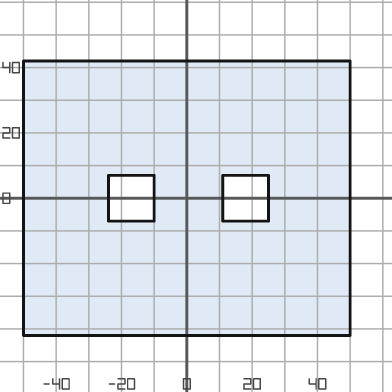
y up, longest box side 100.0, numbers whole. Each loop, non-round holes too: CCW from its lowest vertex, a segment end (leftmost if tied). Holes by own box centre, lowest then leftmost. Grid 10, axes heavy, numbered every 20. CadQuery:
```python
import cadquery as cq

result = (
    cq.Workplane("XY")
    .moveTo(-50.0, -42.0)
    .lineTo(50.0, -42.0)
    .lineTo(50.0, 42.0)
    .lineTo(-50.0, 42.0)
    .close()
    .moveTo(-24.0, -7.0)
    .lineTo(-10.0, -7.0)
    .lineTo(-10.0, 7.0)
    .lineTo(-24.0, 7.0)
    .close()
    .moveTo(11.0, -7.0)
    .lineTo(25.0, -7.0)
    .lineTo(25.0, 7.0)
    .lineTo(11.0, 7.0)
    .close()
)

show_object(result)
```